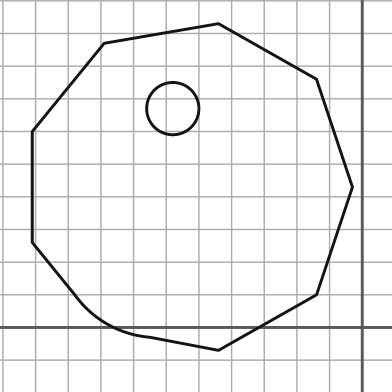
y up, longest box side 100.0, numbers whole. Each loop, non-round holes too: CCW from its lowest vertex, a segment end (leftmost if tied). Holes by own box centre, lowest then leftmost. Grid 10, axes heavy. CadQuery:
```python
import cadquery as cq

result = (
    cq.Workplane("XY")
    .moveTo(-44.0, -7.0)
    .lineTo(-14.0, 10.0)
    .lineTo(-3.0, 43.0)
    .lineTo(-14.0, 76.0)
    .lineTo(-44.0, 93.0)
    .lineTo(-79.0, 87.0)
    .lineTo(-101.0, 60.0)
    .lineTo(-101.0, 26.0)
    .lineTo(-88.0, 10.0)
    .threePointArc((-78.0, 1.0), (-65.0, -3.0))
    .close()
    .moveTo(-58.0, 67.0)
    .circle(8.0)
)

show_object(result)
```